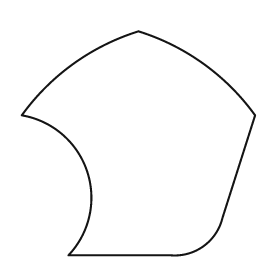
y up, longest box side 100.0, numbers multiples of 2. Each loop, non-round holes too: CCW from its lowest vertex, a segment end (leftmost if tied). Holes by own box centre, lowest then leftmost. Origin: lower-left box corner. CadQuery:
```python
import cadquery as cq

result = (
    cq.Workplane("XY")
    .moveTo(20.0, 0.0)
    .lineTo(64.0, 0.0)
    .threePointArc((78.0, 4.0), (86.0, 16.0))
    .lineTo(100.0, 60.0)
    .threePointArc((78.0, 82.0), (50.0, 96.0))
    .threePointArc((22.0, 82.0), (0.0, 60.0))
    .threePointArc((28.0, 36.0), (20.0, 0.0))
    .close()
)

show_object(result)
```